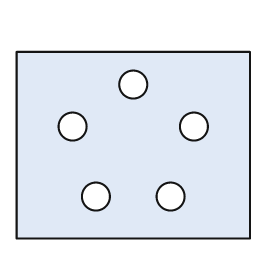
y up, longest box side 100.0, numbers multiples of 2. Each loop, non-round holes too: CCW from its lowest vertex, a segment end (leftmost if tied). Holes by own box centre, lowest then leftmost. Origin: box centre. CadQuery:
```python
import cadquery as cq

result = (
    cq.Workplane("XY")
    .moveTo(-50.0, -40.0)
    .lineTo(50.0, -40.0)
    .lineTo(50.0, 40.0)
    .lineTo(-50.0, 40.0)
    .close()
    .moveTo(-16.0, -22.0)
    .circle(6.0)
    .moveTo(16.0, -22.0)
    .circle(6.0)
    .moveTo(-26.0, 8.0)
    .circle(6.0)
    .moveTo(26.0, 8.0)
    .circle(6.0)
    .moveTo(0.0, 26.0)
    .circle(6.0)
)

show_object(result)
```